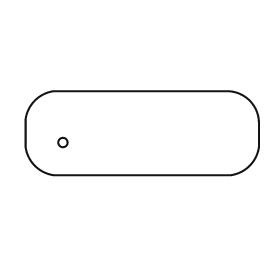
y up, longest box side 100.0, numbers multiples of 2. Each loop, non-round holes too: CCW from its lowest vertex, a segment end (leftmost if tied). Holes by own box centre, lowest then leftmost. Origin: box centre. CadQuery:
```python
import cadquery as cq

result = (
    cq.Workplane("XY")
    .moveTo(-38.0, -18.0)
    .lineTo(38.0, -18.0)
    .threePointArc((46.0, -14.0), (50.0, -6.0))
    .lineTo(50.0, 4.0)
    .threePointArc((46.0, 14.0), (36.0, 18.0))
    .lineTo(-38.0, 18.0)
    .threePointArc((-46.0, 14.0), (-50.0, 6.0))
    .lineTo(-50.0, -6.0)
    .threePointArc((-46.0, -14.0), (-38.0, -18.0))
    .close()
    .moveTo(-34.0, -4.0)
    .circle(2.0)
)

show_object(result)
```